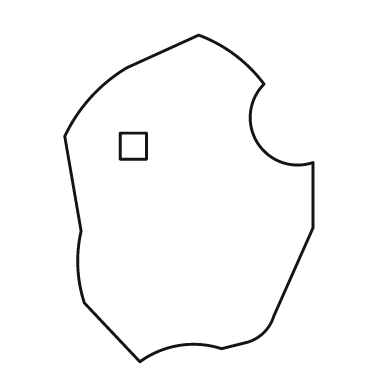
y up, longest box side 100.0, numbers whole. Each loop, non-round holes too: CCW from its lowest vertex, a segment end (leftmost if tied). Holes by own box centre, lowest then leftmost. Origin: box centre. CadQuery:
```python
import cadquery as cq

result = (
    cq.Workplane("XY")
    .moveTo(-15.0, -50.0)
    .threePointArc((-3.0, -45.0), (10.0, -46.0))
    .lineTo(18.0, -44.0)
    .threePointArc((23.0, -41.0), (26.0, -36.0))
    .lineTo(38.0, -9.0)
    .lineTo(38.0, 11.0)
    .threePointArc((21.0, 17.0), (23.0, 35.0))
    .threePointArc((14.0, 44.0), (3.0, 50.0))
    .lineTo(-19.0, 40.0)
    .threePointArc((-30.0, 31.0), (-38.0, 19.0))
    .lineTo(-33.0, -10.0)
    .threePointArc((-34.0, -21.0), (-32.0, -32.0))
    .close()
    .moveTo(-21.0, 12.0)
    .lineTo(-13.0, 12.0)
    .lineTo(-13.0, 20.0)
    .lineTo(-21.0, 20.0)
    .close()
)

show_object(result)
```